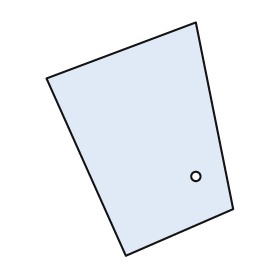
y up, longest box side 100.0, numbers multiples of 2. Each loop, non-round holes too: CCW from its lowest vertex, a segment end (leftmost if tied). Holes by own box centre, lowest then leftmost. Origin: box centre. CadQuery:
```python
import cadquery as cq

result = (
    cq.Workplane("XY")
    .moveTo(-6.0, -50.0)
    .lineTo(40.0, -30.0)
    .lineTo(24.0, 50.0)
    .lineTo(-40.0, 26.0)
    .close()
    .moveTo(24.0, -16.0)
    .circle(2.0)
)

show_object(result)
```